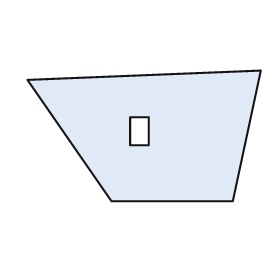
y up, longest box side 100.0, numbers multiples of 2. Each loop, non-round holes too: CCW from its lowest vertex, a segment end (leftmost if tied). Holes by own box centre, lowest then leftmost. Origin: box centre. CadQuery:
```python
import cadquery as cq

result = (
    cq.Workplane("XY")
    .moveTo(-14.0, -28.0)
    .lineTo(38.0, -28.0)
    .lineTo(50.0, 28.0)
    .lineTo(-50.0, 24.0)
    .close()
    .moveTo(-6.0, -4.0)
    .lineTo(2.0, -4.0)
    .lineTo(2.0, 8.0)
    .lineTo(-6.0, 8.0)
    .close()
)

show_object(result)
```